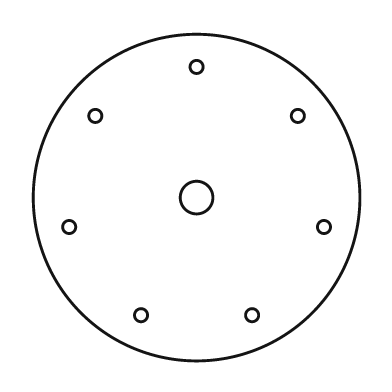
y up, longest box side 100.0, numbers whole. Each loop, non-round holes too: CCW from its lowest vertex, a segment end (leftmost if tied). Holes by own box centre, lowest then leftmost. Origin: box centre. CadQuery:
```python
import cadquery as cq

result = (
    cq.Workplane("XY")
    .moveTo(0.0, 0.0)
    .circle(50.0)
    .moveTo(-17.0, -36.0)
    .circle(2.0)
    .moveTo(17.0, -36.0)
    .circle(2.0)
    .moveTo(-39.0, -9.0)
    .circle(2.0)
    .moveTo(39.0, -9.0)
    .circle(2.0)
    .moveTo(0.0, 0.0)
    .circle(5.0)
    .moveTo(-31.0, 25.0)
    .circle(2.0)
    .moveTo(31.0, 25.0)
    .circle(2.0)
    .moveTo(0.0, 40.0)
    .circle(2.0)
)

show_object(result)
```